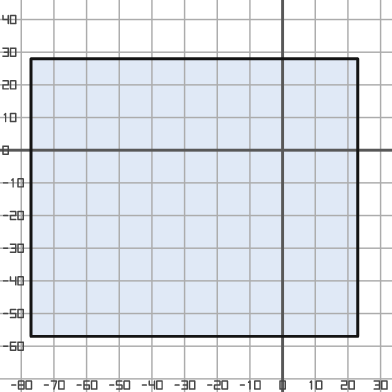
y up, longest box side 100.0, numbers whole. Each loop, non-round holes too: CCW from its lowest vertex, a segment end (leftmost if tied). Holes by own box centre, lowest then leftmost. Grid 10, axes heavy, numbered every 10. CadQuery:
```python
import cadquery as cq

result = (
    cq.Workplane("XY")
    .moveTo(-77.0, -57.0)
    .lineTo(23.0, -57.0)
    .lineTo(23.0, 28.0)
    .lineTo(-77.0, 28.0)
    .close()
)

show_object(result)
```